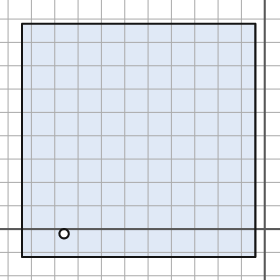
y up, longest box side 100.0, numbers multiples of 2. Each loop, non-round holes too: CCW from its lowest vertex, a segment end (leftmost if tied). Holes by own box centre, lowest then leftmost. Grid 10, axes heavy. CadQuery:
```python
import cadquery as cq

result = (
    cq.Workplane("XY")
    .moveTo(-104.0, -12.0)
    .lineTo(-4.0, -12.0)
    .lineTo(-4.0, 88.0)
    .lineTo(-104.0, 88.0)
    .close()
    .moveTo(-86.0, -2.0)
    .circle(2.0)
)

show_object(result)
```